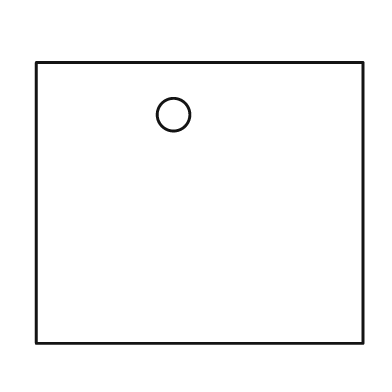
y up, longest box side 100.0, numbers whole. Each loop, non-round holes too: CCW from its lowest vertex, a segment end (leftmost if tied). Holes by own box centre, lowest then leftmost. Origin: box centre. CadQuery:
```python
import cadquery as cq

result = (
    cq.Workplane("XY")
    .moveTo(-50.0, -43.0)
    .lineTo(50.0, -43.0)
    .lineTo(50.0, 43.0)
    .lineTo(-50.0, 43.0)
    .close()
    .moveTo(-8.0, 27.0)
    .circle(5.0)
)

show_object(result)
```